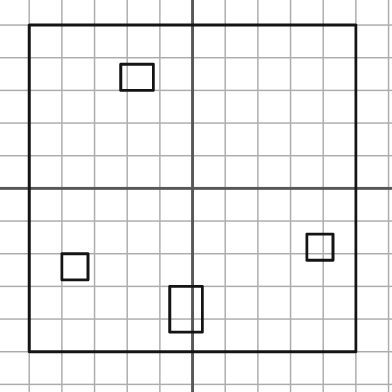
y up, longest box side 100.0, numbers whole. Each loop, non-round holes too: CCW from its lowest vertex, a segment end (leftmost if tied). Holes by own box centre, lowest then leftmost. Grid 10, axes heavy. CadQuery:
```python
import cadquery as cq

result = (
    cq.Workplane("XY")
    .moveTo(-50.0, -50.0)
    .lineTo(50.0, -50.0)
    .lineTo(50.0, 50.0)
    .lineTo(-50.0, 50.0)
    .close()
    .moveTo(-7.0, -44.0)
    .lineTo(3.0, -44.0)
    .lineTo(3.0, -30.0)
    .lineTo(-7.0, -30.0)
    .close()
    .moveTo(-40.0, -28.0)
    .lineTo(-32.0, -28.0)
    .lineTo(-32.0, -20.0)
    .lineTo(-40.0, -20.0)
    .close()
    .moveTo(35.0, -22.0)
    .lineTo(43.0, -22.0)
    .lineTo(43.0, -14.0)
    .lineTo(35.0, -14.0)
    .close()
    .moveTo(-22.0, 30.0)
    .lineTo(-12.0, 30.0)
    .lineTo(-12.0, 38.0)
    .lineTo(-22.0, 38.0)
    .close()
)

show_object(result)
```